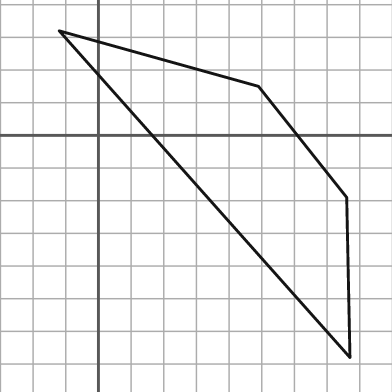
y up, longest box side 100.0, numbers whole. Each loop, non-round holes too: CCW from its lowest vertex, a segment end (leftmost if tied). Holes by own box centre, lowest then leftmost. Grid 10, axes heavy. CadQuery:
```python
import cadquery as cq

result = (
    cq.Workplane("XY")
    .moveTo(77.0, -68.0)
    .lineTo(76.0, -19.0)
    .lineTo(49.0, 15.0)
    .lineTo(-12.0, 32.0)
    .close()
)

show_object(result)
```